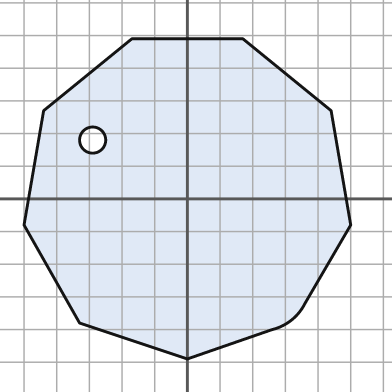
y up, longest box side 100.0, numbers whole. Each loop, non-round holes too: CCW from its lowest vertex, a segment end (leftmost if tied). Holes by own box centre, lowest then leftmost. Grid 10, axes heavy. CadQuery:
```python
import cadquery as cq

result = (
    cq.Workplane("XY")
    .moveTo(0.0, -49.0)
    .lineTo(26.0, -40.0)
    .threePointArc((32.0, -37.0), (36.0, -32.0))
    .lineTo(50.0, -8.0)
    .lineTo(44.0, 27.0)
    .lineTo(17.0, 49.0)
    .lineTo(-17.0, 49.0)
    .lineTo(-44.0, 27.0)
    .lineTo(-50.0, -8.0)
    .lineTo(-33.0, -38.0)
    .close()
    .moveTo(-29.0, 18.0)
    .circle(4.0)
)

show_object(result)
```